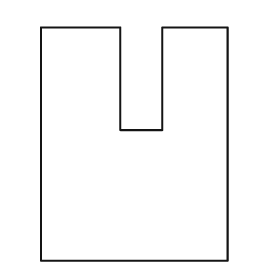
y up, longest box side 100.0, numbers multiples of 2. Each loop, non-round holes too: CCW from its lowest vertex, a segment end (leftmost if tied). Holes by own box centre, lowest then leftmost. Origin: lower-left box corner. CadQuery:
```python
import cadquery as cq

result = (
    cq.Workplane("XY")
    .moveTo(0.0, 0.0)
    .lineTo(80.0, 0.0)
    .lineTo(80.0, 100.0)
    .lineTo(52.0, 100.0)
    .lineTo(52.0, 56.0)
    .lineTo(34.0, 56.0)
    .lineTo(34.0, 100.0)
    .lineTo(0.0, 100.0)
    .close()
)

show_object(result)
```